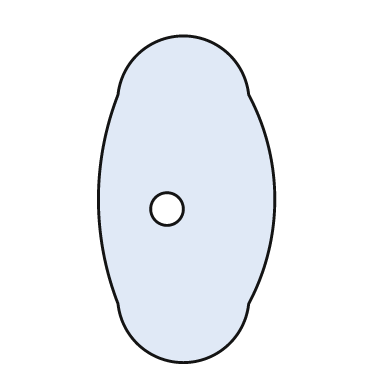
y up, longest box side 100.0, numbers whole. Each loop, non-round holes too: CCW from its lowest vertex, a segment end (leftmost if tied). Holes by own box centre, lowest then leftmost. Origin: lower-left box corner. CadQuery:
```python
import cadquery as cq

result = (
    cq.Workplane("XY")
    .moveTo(6.0, 18.0)
    .threePointArc((26.0, 0.0), (46.0, 18.0))
    .threePointArc((54.0, 50.0), (46.0, 82.0))
    .threePointArc((26.0, 100.0), (6.0, 82.0))
    .threePointArc((0.0, 50.0), (6.0, 18.0))
    .close()
    .moveTo(21.0, 47.0)
    .circle(5.0)
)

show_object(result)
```